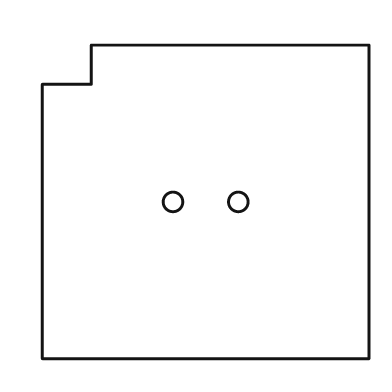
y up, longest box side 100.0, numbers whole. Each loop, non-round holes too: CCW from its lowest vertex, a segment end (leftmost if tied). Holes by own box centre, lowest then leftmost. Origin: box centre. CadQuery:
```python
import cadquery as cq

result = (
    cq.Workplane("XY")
    .moveTo(-50.0, -48.0)
    .lineTo(50.0, -48.0)
    .lineTo(50.0, 48.0)
    .lineTo(-35.0, 48.0)
    .lineTo(-35.0, 36.0)
    .lineTo(-50.0, 36.0)
    .close()
    .moveTo(-10.0, 0.0)
    .circle(3.0)
    .moveTo(10.0, 0.0)
    .circle(3.0)
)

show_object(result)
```